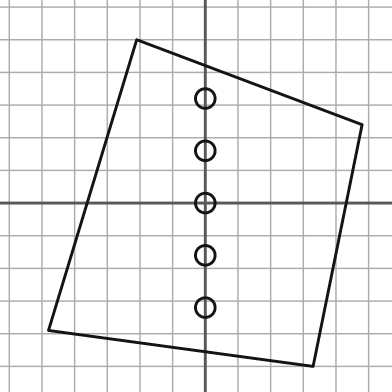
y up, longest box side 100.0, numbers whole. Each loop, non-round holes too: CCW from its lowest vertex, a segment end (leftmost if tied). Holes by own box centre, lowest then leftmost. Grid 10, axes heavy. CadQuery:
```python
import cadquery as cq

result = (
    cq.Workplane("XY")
    .moveTo(33.0, -50.0)
    .lineTo(48.0, 24.0)
    .lineTo(-21.0, 50.0)
    .lineTo(-48.0, -39.0)
    .close()
    .moveTo(0.0, -32.0)
    .circle(3.0)
    .moveTo(0.0, -16.0)
    .circle(3.0)
    .moveTo(0.0, 0.0)
    .circle(3.0)
    .moveTo(0.0, 16.0)
    .circle(3.0)
    .moveTo(0.0, 32.0)
    .circle(3.0)
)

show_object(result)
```